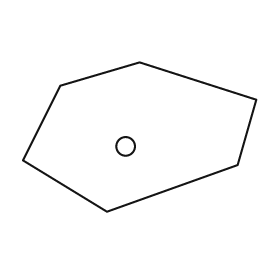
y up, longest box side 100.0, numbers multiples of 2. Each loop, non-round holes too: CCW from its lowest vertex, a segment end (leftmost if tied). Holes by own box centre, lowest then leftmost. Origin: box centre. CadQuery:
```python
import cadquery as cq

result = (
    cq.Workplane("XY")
    .moveTo(-14.0, -32.0)
    .lineTo(42.0, -12.0)
    .lineTo(50.0, 16.0)
    .lineTo(0.0, 32.0)
    .lineTo(-34.0, 22.0)
    .lineTo(-50.0, -10.0)
    .close()
    .moveTo(-6.0, -4.0)
    .circle(4.0)
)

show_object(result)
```